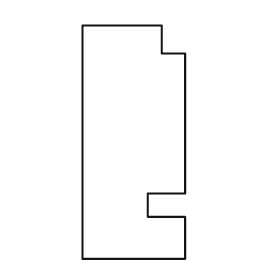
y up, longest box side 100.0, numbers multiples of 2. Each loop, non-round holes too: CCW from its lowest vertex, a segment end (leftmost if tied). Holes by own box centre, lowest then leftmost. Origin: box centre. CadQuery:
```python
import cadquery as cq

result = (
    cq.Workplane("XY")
    .moveTo(-22.0, -50.0)
    .lineTo(22.0, -50.0)
    .lineTo(22.0, -32.0)
    .lineTo(6.0, -32.0)
    .lineTo(6.0, -22.0)
    .lineTo(22.0, -22.0)
    .lineTo(22.0, 38.0)
    .lineTo(12.0, 38.0)
    .lineTo(12.0, 50.0)
    .lineTo(-22.0, 50.0)
    .close()
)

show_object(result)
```